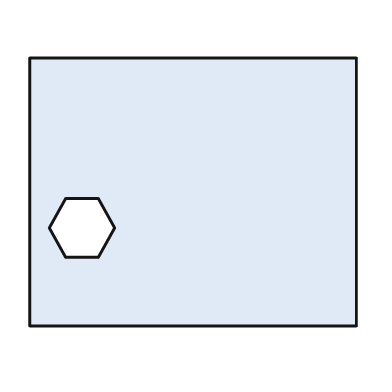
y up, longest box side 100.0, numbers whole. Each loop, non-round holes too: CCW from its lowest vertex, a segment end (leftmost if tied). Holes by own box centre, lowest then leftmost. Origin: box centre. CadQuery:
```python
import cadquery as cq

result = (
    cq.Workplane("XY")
    .moveTo(-50.0, -41.0)
    .lineTo(50.0, -41.0)
    .lineTo(50.0, 41.0)
    .lineTo(-50.0, 41.0)
    .close()
    .moveTo(-39.0, -20.0)
    .lineTo(-29.0, -20.0)
    .lineTo(-24.0, -11.0)
    .lineTo(-29.0, -2.0)
    .lineTo(-39.0, -2.0)
    .lineTo(-44.0, -11.0)
    .close()
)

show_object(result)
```